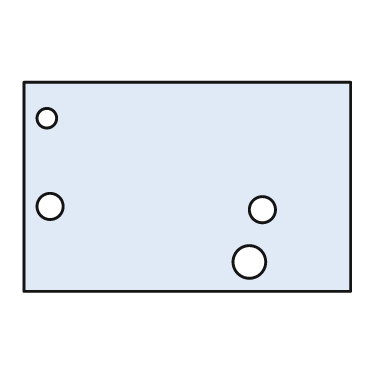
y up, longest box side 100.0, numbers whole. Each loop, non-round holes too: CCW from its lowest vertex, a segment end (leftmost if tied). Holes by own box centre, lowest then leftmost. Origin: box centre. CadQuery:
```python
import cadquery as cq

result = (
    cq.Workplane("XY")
    .moveTo(-50.0, -32.0)
    .lineTo(50.0, -32.0)
    .lineTo(50.0, 32.0)
    .lineTo(-50.0, 32.0)
    .close()
    .moveTo(19.0, -23.0)
    .circle(5.0)
    .moveTo(23.0, -7.0)
    .circle(4.0)
    .moveTo(-42.0, -6.0)
    .circle(4.0)
    .moveTo(-43.0, 21.0)
    .circle(3.0)
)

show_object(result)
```